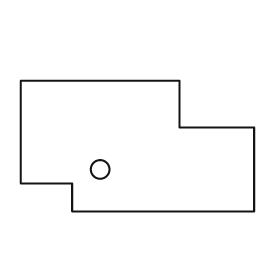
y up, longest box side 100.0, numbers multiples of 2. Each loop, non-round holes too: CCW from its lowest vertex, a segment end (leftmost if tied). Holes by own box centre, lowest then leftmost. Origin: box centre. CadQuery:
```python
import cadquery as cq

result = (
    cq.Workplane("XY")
    .moveTo(-28.0, -28.0)
    .lineTo(50.0, -28.0)
    .lineTo(50.0, 8.0)
    .lineTo(18.0, 8.0)
    .lineTo(18.0, 28.0)
    .lineTo(-50.0, 28.0)
    .lineTo(-50.0, -16.0)
    .lineTo(-28.0, -16.0)
    .close()
    .moveTo(-16.0, -10.0)
    .circle(4.0)
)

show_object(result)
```